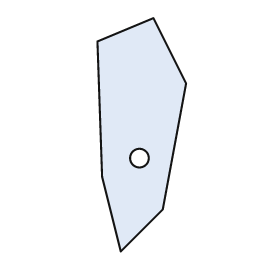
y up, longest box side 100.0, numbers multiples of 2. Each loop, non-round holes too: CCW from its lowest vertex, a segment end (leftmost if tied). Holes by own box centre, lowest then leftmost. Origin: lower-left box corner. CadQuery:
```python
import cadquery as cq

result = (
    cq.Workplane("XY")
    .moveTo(10.0, 0.0)
    .lineTo(28.0, 18.0)
    .lineTo(38.0, 72.0)
    .lineTo(24.0, 100.0)
    .lineTo(0.0, 90.0)
    .lineTo(2.0, 32.0)
    .close()
    .moveTo(18.0, 40.0)
    .circle(4.0)
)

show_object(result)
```